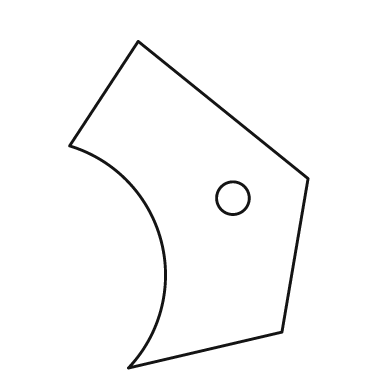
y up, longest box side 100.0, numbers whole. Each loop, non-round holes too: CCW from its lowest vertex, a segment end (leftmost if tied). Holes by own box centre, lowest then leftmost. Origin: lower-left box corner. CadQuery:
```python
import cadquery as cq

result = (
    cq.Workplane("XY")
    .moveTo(18.0, 0.0)
    .lineTo(65.0, 11.0)
    .lineTo(73.0, 58.0)
    .lineTo(21.0, 100.0)
    .lineTo(0.0, 68.0)
    .threePointArc((28.0, 39.0), (18.0, 0.0))
    .close()
    .moveTo(50.0, 52.0)
    .circle(5.0)
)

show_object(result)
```